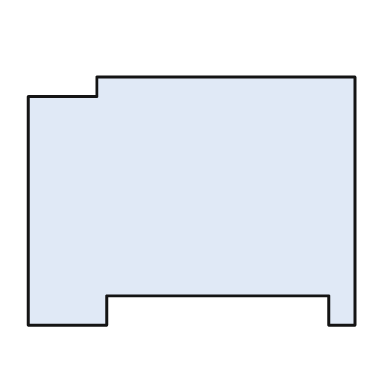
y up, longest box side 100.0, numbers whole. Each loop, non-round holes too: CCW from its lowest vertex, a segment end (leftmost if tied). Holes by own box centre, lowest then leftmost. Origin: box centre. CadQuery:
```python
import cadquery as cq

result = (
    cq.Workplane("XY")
    .moveTo(-50.0, -38.0)
    .lineTo(-26.0, -38.0)
    .lineTo(-26.0, -29.0)
    .lineTo(42.0, -29.0)
    .lineTo(42.0, -38.0)
    .lineTo(50.0, -38.0)
    .lineTo(50.0, 38.0)
    .lineTo(-29.0, 38.0)
    .lineTo(-29.0, 32.0)
    .lineTo(-50.0, 32.0)
    .close()
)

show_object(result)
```